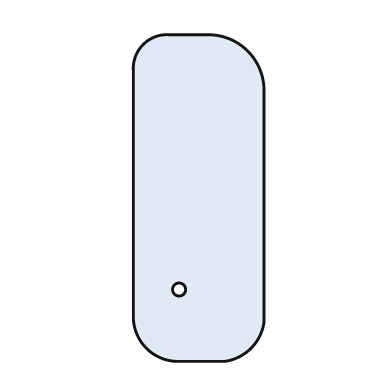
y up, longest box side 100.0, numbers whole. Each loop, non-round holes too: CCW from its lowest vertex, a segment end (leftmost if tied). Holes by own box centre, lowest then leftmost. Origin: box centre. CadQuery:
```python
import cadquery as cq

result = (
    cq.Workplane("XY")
    .moveTo(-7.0, -50.0)
    .lineTo(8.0, -50.0)
    .threePointArc((16.0, -46.0), (20.0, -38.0))
    .lineTo(20.0, 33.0)
    .threePointArc((15.0, 45.0), (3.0, 50.0))
    .lineTo(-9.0, 50.0)
    .threePointArc((-17.0, 47.0), (-20.0, 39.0))
    .lineTo(-20.0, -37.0)
    .threePointArc((-16.0, -46.0), (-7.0, -50.0))
    .close()
    .moveTo(-6.0, -28.0)
    .circle(2.0)
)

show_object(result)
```